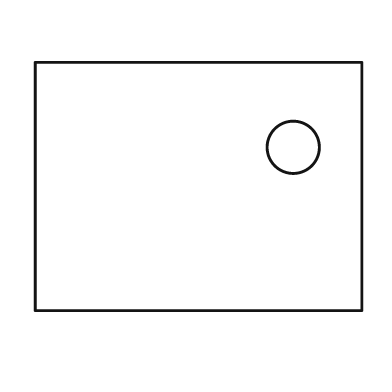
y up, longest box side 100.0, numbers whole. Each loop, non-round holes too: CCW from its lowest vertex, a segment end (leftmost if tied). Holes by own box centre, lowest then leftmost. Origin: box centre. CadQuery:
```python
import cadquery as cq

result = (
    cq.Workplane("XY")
    .moveTo(-50.0, -38.0)
    .lineTo(50.0, -38.0)
    .lineTo(50.0, 38.0)
    .lineTo(-50.0, 38.0)
    .close()
    .moveTo(29.0, 12.0)
    .circle(8.0)
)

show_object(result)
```